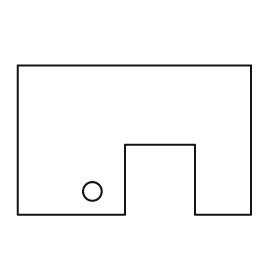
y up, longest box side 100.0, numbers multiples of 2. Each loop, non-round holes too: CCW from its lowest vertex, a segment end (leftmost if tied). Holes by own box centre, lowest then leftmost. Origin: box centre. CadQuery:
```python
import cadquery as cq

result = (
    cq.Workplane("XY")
    .moveTo(-50.0, -32.0)
    .lineTo(-4.0, -32.0)
    .lineTo(-4.0, -2.0)
    .lineTo(26.0, -2.0)
    .lineTo(26.0, -32.0)
    .lineTo(50.0, -32.0)
    .lineTo(50.0, 32.0)
    .lineTo(-50.0, 32.0)
    .close()
    .moveTo(-18.0, -22.0)
    .circle(4.0)
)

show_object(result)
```